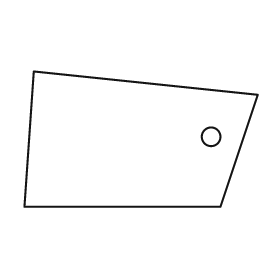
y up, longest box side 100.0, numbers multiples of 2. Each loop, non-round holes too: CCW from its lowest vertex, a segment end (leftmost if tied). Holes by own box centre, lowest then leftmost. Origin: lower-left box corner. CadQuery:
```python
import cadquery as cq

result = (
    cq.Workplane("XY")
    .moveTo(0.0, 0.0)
    .lineTo(84.0, 0.0)
    .lineTo(100.0, 48.0)
    .lineTo(4.0, 58.0)
    .close()
    .moveTo(80.0, 30.0)
    .circle(4.0)
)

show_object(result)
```